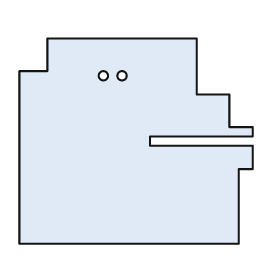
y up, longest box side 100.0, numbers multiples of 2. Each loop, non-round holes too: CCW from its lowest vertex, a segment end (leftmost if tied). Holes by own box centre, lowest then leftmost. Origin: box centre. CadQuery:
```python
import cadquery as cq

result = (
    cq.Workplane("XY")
    .moveTo(-50.0, -44.0)
    .lineTo(44.0, -44.0)
    .lineTo(44.0, -12.0)
    .lineTo(50.0, -12.0)
    .lineTo(50.0, -2.0)
    .lineTo(6.0, -2.0)
    .lineTo(6.0, 2.0)
    .lineTo(50.0, 2.0)
    .lineTo(50.0, 6.0)
    .lineTo(40.0, 6.0)
    .lineTo(40.0, 20.0)
    .lineTo(26.0, 20.0)
    .lineTo(26.0, 44.0)
    .lineTo(-38.0, 44.0)
    .lineTo(-38.0, 30.0)
    .lineTo(-50.0, 30.0)
    .close()
    .moveTo(-14.0, 28.0)
    .circle(2.0)
    .moveTo(-6.0, 28.0)
    .circle(2.0)
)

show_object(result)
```